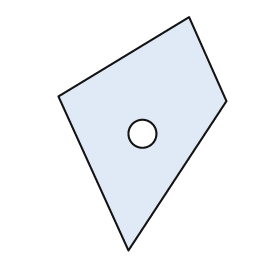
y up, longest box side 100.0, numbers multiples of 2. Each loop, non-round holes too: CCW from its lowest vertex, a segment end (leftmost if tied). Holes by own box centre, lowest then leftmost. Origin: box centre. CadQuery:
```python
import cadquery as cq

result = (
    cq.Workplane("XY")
    .moveTo(-6.0, -50.0)
    .lineTo(36.0, 14.0)
    .lineTo(20.0, 50.0)
    .lineTo(-36.0, 16.0)
    .close()
    .moveTo(0.0, 0.0)
    .circle(6.0)
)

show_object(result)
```